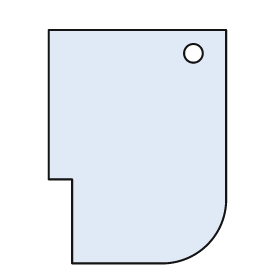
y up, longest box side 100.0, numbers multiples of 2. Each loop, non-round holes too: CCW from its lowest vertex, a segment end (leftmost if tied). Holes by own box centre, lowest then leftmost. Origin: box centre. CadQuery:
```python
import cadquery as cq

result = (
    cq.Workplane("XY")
    .moveTo(-28.0, -50.0)
    .lineTo(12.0, -50.0)
    .threePointArc((30.0, -42.0), (38.0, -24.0))
    .lineTo(38.0, 50.0)
    .lineTo(-38.0, 50.0)
    .lineTo(-38.0, -14.0)
    .lineTo(-28.0, -14.0)
    .close()
    .moveTo(24.0, 40.0)
    .circle(4.0)
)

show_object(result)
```